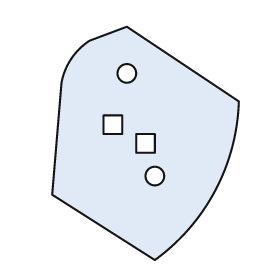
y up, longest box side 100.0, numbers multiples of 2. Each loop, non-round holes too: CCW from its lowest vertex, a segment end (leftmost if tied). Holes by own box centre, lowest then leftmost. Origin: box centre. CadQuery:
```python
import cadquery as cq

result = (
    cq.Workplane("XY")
    .moveTo(4.0, -50.0)
    .threePointArc((30.0, -20.0), (40.0, 18.0))
    .lineTo(-8.0, 50.0)
    .lineTo(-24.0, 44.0)
    .threePointArc((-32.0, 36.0), (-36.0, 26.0))
    .lineTo(-40.0, -22.0)
    .close()
    .moveTo(4.0, -14.0)
    .circle(4.0)
    .moveTo(-4.0, -4.0)
    .lineTo(4.0, -4.0)
    .lineTo(4.0, 4.0)
    .lineTo(-4.0, 4.0)
    .close()
    .moveTo(-18.0, 4.0)
    .lineTo(-10.0, 4.0)
    .lineTo(-10.0, 12.0)
    .lineTo(-18.0, 12.0)
    .close()
    .moveTo(-8.0, 30.0)
    .circle(4.0)
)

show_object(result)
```